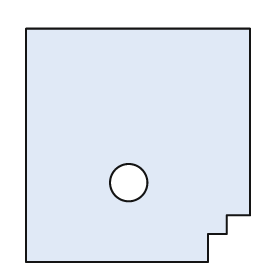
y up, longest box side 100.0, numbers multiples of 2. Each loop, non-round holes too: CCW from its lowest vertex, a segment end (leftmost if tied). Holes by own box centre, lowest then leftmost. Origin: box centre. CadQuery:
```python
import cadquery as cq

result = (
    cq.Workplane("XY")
    .moveTo(-48.0, -50.0)
    .lineTo(30.0, -50.0)
    .lineTo(30.0, -38.0)
    .lineTo(38.0, -38.0)
    .lineTo(38.0, -30.0)
    .lineTo(48.0, -30.0)
    .lineTo(48.0, 50.0)
    .lineTo(-48.0, 50.0)
    .close()
    .moveTo(-4.0, -16.0)
    .circle(8.0)
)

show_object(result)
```